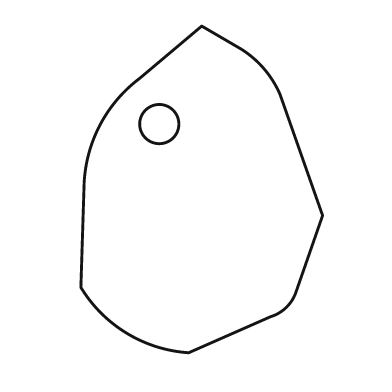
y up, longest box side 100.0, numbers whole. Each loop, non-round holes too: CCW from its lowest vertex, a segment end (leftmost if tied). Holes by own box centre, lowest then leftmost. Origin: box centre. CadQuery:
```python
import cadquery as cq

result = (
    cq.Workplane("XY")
    .moveTo(-4.0, -50.0)
    .lineTo(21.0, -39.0)
    .threePointArc((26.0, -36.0), (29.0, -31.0))
    .lineTo(37.0, -8.0)
    .lineTo(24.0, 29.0)
    .threePointArc((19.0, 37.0), (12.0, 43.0))
    .lineTo(0.0, 50.0)
    .lineTo(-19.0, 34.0)
    .threePointArc((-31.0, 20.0), (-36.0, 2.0))
    .lineTo(-37.0, -30.0)
    .threePointArc((-23.0, -44.0), (-4.0, -50.0))
    .close()
    .moveTo(-13.0, 20.0)
    .circle(6.0)
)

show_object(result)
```